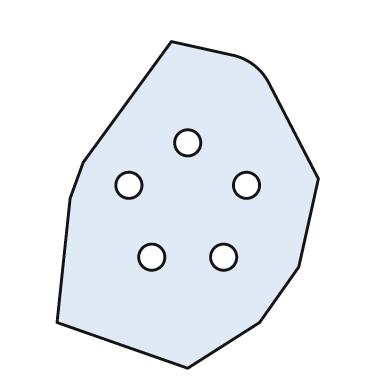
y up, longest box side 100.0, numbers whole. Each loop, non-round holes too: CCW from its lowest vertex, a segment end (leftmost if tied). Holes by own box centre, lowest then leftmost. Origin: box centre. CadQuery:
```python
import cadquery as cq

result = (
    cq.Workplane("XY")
    .moveTo(0.0, -50.0)
    .lineTo(22.0, -36.0)
    .lineTo(34.0, -19.0)
    .lineTo(40.0, 8.0)
    .lineTo(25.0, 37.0)
    .threePointArc((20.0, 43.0), (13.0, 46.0))
    .lineTo(-5.0, 50.0)
    .lineTo(-32.0, 13.0)
    .lineTo(-36.0, 2.0)
    .lineTo(-40.0, -36.0)
    .close()
    .moveTo(-11.0, -16.0)
    .circle(4.0)
    .moveTo(11.0, -16.0)
    .circle(4.0)
    .moveTo(-18.0, 6.0)
    .circle(4.0)
    .moveTo(18.0, 6.0)
    .circle(4.0)
    .moveTo(0.0, 19.0)
    .circle(4.0)
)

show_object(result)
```